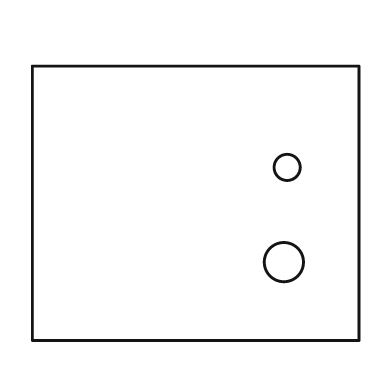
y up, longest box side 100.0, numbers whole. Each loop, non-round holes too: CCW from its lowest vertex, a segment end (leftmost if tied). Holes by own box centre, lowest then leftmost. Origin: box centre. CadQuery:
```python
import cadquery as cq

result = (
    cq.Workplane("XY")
    .moveTo(-50.0, -42.0)
    .lineTo(50.0, -42.0)
    .lineTo(50.0, 42.0)
    .lineTo(-50.0, 42.0)
    .close()
    .moveTo(27.0, -18.0)
    .circle(6.0)
    .moveTo(28.0, 11.0)
    .circle(4.0)
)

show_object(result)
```